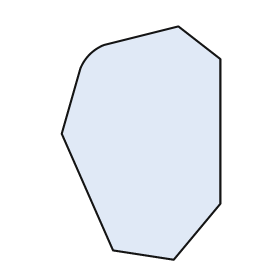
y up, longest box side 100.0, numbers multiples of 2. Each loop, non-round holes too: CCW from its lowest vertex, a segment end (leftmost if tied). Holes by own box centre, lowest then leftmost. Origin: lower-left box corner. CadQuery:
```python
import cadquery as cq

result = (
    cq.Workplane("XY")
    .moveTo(48.0, 0.0)
    .lineTo(68.0, 24.0)
    .lineTo(68.0, 86.0)
    .lineTo(50.0, 100.0)
    .lineTo(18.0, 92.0)
    .threePointArc((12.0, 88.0), (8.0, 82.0))
    .lineTo(0.0, 54.0)
    .lineTo(22.0, 4.0)
    .close()
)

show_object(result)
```